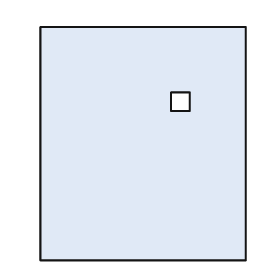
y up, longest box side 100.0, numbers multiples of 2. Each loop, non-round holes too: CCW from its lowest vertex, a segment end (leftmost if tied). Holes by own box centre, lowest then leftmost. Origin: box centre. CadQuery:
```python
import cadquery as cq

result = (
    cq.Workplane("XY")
    .moveTo(-44.0, -50.0)
    .lineTo(44.0, -50.0)
    .lineTo(44.0, 50.0)
    .lineTo(-44.0, 50.0)
    .close()
    .moveTo(12.0, 14.0)
    .lineTo(20.0, 14.0)
    .lineTo(20.0, 22.0)
    .lineTo(12.0, 22.0)
    .close()
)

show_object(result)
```